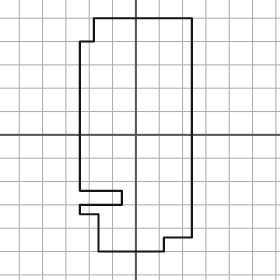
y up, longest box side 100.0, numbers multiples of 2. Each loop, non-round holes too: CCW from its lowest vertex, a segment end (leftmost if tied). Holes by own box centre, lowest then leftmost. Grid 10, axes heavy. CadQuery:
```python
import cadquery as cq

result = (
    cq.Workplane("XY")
    .moveTo(-16.0, -50.0)
    .lineTo(12.0, -50.0)
    .lineTo(12.0, -44.0)
    .lineTo(24.0, -44.0)
    .lineTo(24.0, 50.0)
    .lineTo(-18.0, 50.0)
    .lineTo(-18.0, 40.0)
    .lineTo(-24.0, 40.0)
    .lineTo(-24.0, -24.0)
    .lineTo(-6.0, -24.0)
    .lineTo(-6.0, -30.0)
    .lineTo(-24.0, -30.0)
    .lineTo(-24.0, -34.0)
    .lineTo(-16.0, -34.0)
    .close()
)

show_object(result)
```